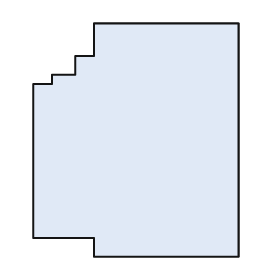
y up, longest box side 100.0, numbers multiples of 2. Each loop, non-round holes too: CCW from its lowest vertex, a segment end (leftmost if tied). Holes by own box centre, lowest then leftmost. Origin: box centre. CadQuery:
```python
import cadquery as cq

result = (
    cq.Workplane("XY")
    .moveTo(-18.0, -50.0)
    .lineTo(44.0, -50.0)
    .lineTo(44.0, 50.0)
    .lineTo(-18.0, 50.0)
    .lineTo(-18.0, 36.0)
    .lineTo(-26.0, 36.0)
    .lineTo(-26.0, 28.0)
    .lineTo(-36.0, 28.0)
    .lineTo(-36.0, 24.0)
    .lineTo(-44.0, 24.0)
    .lineTo(-44.0, -42.0)
    .lineTo(-18.0, -42.0)
    .close()
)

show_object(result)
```